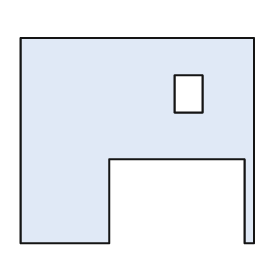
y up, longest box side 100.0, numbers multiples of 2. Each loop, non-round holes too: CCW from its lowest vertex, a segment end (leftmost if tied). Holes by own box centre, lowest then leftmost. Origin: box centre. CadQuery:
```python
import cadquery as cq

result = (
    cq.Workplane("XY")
    .moveTo(-50.0, -44.0)
    .lineTo(-12.0, -44.0)
    .lineTo(-12.0, -8.0)
    .lineTo(46.0, -8.0)
    .lineTo(46.0, -44.0)
    .lineTo(50.0, -44.0)
    .lineTo(50.0, 44.0)
    .lineTo(-50.0, 44.0)
    .close()
    .moveTo(16.0, 12.0)
    .lineTo(28.0, 12.0)
    .lineTo(28.0, 28.0)
    .lineTo(16.0, 28.0)
    .close()
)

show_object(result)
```